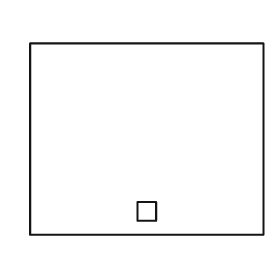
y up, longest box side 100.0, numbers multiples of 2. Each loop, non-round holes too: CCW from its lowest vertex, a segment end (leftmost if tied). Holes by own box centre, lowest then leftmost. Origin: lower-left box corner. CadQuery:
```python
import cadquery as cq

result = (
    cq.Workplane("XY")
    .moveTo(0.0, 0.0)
    .lineTo(100.0, 0.0)
    .lineTo(100.0, 82.0)
    .lineTo(0.0, 82.0)
    .close()
    .moveTo(46.0, 6.0)
    .lineTo(54.0, 6.0)
    .lineTo(54.0, 14.0)
    .lineTo(46.0, 14.0)
    .close()
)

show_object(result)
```